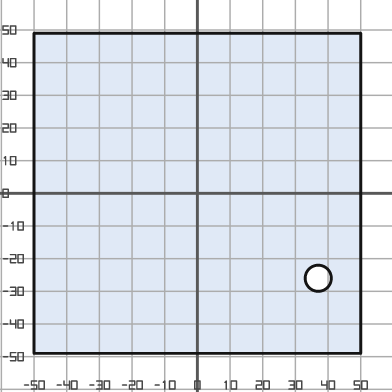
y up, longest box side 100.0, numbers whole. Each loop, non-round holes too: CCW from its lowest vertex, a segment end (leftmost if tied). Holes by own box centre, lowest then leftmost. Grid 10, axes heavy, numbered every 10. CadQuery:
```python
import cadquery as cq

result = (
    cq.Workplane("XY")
    .moveTo(-50.0, -49.0)
    .lineTo(50.0, -49.0)
    .lineTo(50.0, 49.0)
    .lineTo(-50.0, 49.0)
    .close()
    .moveTo(37.0, -26.0)
    .circle(4.0)
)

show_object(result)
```